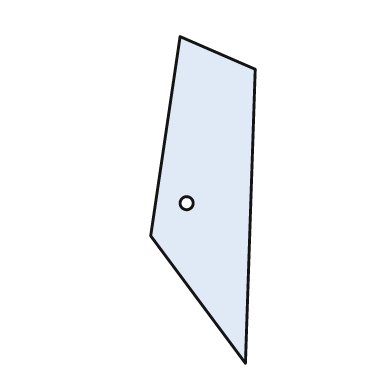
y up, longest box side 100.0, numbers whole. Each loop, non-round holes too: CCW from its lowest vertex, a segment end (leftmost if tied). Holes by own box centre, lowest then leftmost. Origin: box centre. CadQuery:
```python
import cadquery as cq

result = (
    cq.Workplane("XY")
    .moveTo(13.0, -50.0)
    .lineTo(16.0, 40.0)
    .lineTo(-7.0, 50.0)
    .lineTo(-16.0, -11.0)
    .close()
    .moveTo(-5.0, -1.0)
    .circle(2.0)
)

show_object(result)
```